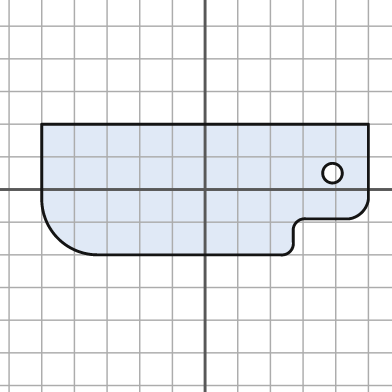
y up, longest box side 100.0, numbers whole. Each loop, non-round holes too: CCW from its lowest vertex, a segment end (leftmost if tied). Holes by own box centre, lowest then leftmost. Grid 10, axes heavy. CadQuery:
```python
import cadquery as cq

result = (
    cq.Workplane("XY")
    .moveTo(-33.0, -20.0)
    .lineTo(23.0, -20.0)
    .threePointArc((26.0, -19.0), (27.0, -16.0))
    .lineTo(27.0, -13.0)
    .threePointArc((28.0, -10.0), (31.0, -9.0))
    .lineTo(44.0, -9.0)
    .threePointArc((48.0, -7.0), (50.0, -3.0))
    .lineTo(50.0, 20.0)
    .lineTo(-50.0, 20.0)
    .lineTo(-50.0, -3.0)
    .threePointArc((-45.0, -15.0), (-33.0, -20.0))
    .close()
    .moveTo(39.0, 5.0)
    .circle(3.0)
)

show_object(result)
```